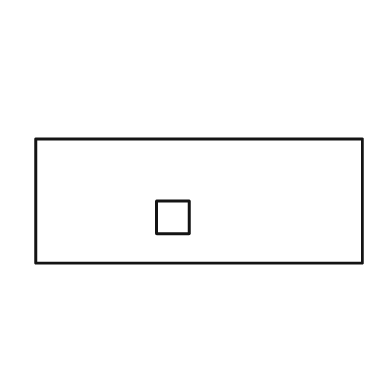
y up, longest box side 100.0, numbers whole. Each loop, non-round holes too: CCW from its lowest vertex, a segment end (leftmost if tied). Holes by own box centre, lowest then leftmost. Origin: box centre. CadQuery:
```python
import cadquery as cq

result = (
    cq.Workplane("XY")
    .moveTo(-50.0, -19.0)
    .lineTo(50.0, -19.0)
    .lineTo(50.0, 19.0)
    .lineTo(-50.0, 19.0)
    .close()
    .moveTo(-13.0, -10.0)
    .lineTo(-3.0, -10.0)
    .lineTo(-3.0, 0.0)
    .lineTo(-13.0, 0.0)
    .close()
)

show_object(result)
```